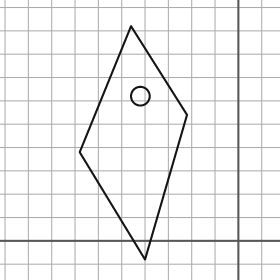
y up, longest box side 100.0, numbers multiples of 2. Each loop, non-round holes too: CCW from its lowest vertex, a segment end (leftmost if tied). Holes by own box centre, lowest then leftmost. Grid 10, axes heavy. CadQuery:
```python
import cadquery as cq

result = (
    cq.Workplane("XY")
    .moveTo(-40.0, -8.0)
    .lineTo(-22.0, 54.0)
    .lineTo(-46.0, 92.0)
    .lineTo(-68.0, 38.0)
    .close()
    .moveTo(-42.0, 62.0)
    .circle(4.0)
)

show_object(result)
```